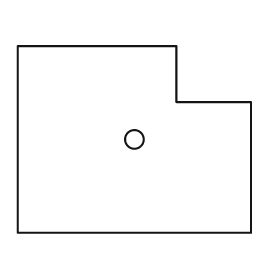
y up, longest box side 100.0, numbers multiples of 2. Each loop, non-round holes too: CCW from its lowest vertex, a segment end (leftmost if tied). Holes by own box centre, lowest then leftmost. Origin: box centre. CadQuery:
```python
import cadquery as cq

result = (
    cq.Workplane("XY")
    .moveTo(-50.0, -40.0)
    .lineTo(50.0, -40.0)
    .lineTo(50.0, 16.0)
    .lineTo(18.0, 16.0)
    .lineTo(18.0, 40.0)
    .lineTo(-50.0, 40.0)
    .close()
    .moveTo(0.0, 0.0)
    .circle(4.0)
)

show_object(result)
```